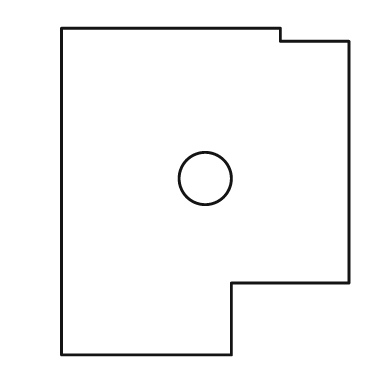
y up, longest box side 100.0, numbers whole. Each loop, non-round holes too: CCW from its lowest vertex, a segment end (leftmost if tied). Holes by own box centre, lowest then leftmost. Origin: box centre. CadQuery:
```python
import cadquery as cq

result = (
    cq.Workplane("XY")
    .moveTo(-44.0, -50.0)
    .lineTo(8.0, -50.0)
    .lineTo(8.0, -28.0)
    .lineTo(44.0, -28.0)
    .lineTo(44.0, 46.0)
    .lineTo(23.0, 46.0)
    .lineTo(23.0, 50.0)
    .lineTo(-44.0, 50.0)
    .close()
    .moveTo(0.0, 4.0)
    .circle(8.0)
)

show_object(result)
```